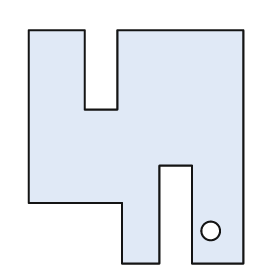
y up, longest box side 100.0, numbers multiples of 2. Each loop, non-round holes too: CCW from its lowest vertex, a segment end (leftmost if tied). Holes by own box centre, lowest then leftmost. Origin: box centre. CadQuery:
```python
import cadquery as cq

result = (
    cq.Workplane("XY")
    .moveTo(-6.0, -50.0)
    .lineTo(10.0, -50.0)
    .lineTo(10.0, -8.0)
    .lineTo(24.0, -8.0)
    .lineTo(24.0, -50.0)
    .lineTo(46.0, -50.0)
    .lineTo(46.0, 50.0)
    .lineTo(-8.0, 50.0)
    .lineTo(-8.0, 16.0)
    .lineTo(-22.0, 16.0)
    .lineTo(-22.0, 50.0)
    .lineTo(-46.0, 50.0)
    .lineTo(-46.0, -24.0)
    .lineTo(-6.0, -24.0)
    .close()
    .moveTo(32.0, -36.0)
    .circle(4.0)
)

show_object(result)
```